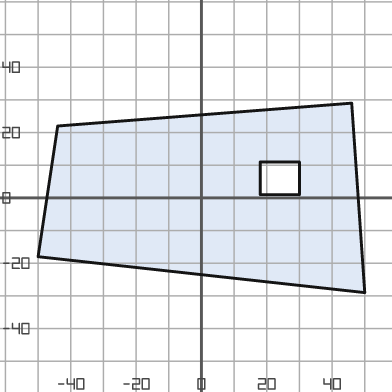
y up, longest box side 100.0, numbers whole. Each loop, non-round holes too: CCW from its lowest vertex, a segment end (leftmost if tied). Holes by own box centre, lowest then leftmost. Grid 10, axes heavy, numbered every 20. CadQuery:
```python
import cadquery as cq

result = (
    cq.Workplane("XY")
    .moveTo(50.0, -29.0)
    .lineTo(46.0, 29.0)
    .lineTo(-44.0, 22.0)
    .lineTo(-50.0, -18.0)
    .close()
    .moveTo(18.0, 1.0)
    .lineTo(30.0, 1.0)
    .lineTo(30.0, 11.0)
    .lineTo(18.0, 11.0)
    .close()
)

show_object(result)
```